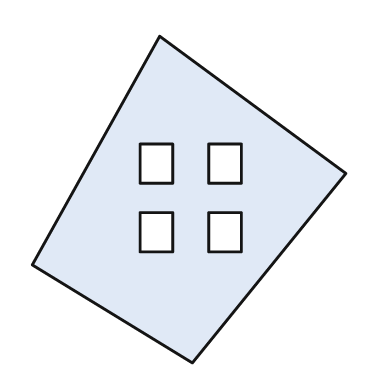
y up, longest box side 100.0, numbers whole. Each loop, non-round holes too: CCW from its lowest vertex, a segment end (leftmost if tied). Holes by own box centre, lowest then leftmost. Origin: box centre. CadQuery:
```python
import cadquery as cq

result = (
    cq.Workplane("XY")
    .moveTo(1.0, -50.0)
    .lineTo(48.0, 8.0)
    .lineTo(-9.0, 50.0)
    .lineTo(-48.0, -20.0)
    .close()
    .moveTo(-15.0, -16.0)
    .lineTo(-5.0, -16.0)
    .lineTo(-5.0, -4.0)
    .lineTo(-15.0, -4.0)
    .close()
    .moveTo(6.0, -16.0)
    .lineTo(16.0, -16.0)
    .lineTo(16.0, -4.0)
    .lineTo(6.0, -4.0)
    .close()
    .moveTo(-15.0, 5.0)
    .lineTo(-5.0, 5.0)
    .lineTo(-5.0, 17.0)
    .lineTo(-15.0, 17.0)
    .close()
    .moveTo(6.0, 5.0)
    .lineTo(16.0, 5.0)
    .lineTo(16.0, 17.0)
    .lineTo(6.0, 17.0)
    .close()
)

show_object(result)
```